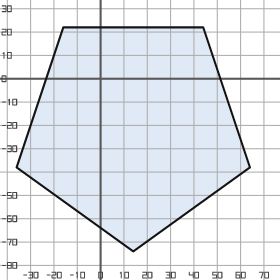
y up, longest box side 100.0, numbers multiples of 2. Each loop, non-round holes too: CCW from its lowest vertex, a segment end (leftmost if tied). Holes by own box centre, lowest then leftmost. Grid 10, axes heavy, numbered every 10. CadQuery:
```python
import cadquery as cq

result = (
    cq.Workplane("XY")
    .moveTo(14.0, -74.0)
    .lineTo(64.0, -38.0)
    .lineTo(44.0, 22.0)
    .lineTo(-16.0, 22.0)
    .lineTo(-36.0, -38.0)
    .close()
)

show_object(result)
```